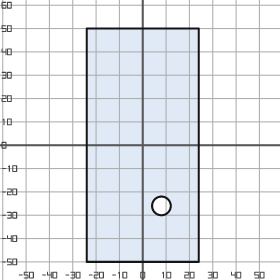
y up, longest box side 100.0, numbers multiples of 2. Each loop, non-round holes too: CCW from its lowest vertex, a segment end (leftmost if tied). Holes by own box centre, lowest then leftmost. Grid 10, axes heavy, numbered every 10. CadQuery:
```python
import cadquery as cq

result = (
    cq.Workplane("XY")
    .moveTo(-24.0, -50.0)
    .lineTo(24.0, -50.0)
    .lineTo(24.0, 50.0)
    .lineTo(-24.0, 50.0)
    .close()
    .moveTo(8.0, -26.0)
    .circle(4.0)
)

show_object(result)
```